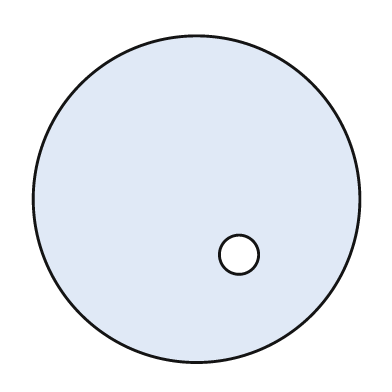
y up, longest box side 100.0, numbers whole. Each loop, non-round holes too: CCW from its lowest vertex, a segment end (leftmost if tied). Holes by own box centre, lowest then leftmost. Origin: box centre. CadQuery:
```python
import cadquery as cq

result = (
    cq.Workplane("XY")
    .moveTo(0.0, 0.0)
    .circle(50.0)
    .moveTo(13.0, -17.0)
    .circle(6.0)
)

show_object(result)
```